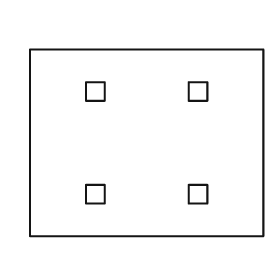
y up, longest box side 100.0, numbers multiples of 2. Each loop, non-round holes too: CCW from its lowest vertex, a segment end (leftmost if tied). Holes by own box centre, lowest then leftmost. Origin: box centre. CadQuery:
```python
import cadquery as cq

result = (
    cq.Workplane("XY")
    .moveTo(-50.0, -40.0)
    .lineTo(50.0, -40.0)
    .lineTo(50.0, 40.0)
    .lineTo(-50.0, 40.0)
    .close()
    .moveTo(-26.0, -26.0)
    .lineTo(-18.0, -26.0)
    .lineTo(-18.0, -18.0)
    .lineTo(-26.0, -18.0)
    .close()
    .moveTo(18.0, -26.0)
    .lineTo(26.0, -26.0)
    .lineTo(26.0, -18.0)
    .lineTo(18.0, -18.0)
    .close()
    .moveTo(-26.0, 18.0)
    .lineTo(-18.0, 18.0)
    .lineTo(-18.0, 26.0)
    .lineTo(-26.0, 26.0)
    .close()
    .moveTo(18.0, 18.0)
    .lineTo(26.0, 18.0)
    .lineTo(26.0, 26.0)
    .lineTo(18.0, 26.0)
    .close()
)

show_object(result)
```